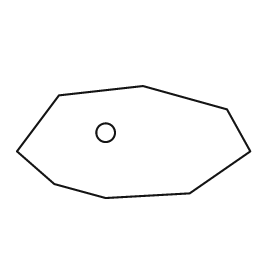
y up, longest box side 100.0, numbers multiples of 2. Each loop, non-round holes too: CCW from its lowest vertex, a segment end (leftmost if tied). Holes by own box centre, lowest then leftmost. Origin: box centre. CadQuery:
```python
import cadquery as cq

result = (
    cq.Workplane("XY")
    .moveTo(-12.0, -24.0)
    .lineTo(24.0, -22.0)
    .lineTo(50.0, -4.0)
    .lineTo(40.0, 14.0)
    .lineTo(4.0, 24.0)
    .lineTo(-32.0, 20.0)
    .lineTo(-50.0, -4.0)
    .lineTo(-34.0, -18.0)
    .close()
    .moveTo(-12.0, 4.0)
    .circle(4.0)
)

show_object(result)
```